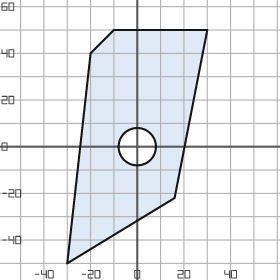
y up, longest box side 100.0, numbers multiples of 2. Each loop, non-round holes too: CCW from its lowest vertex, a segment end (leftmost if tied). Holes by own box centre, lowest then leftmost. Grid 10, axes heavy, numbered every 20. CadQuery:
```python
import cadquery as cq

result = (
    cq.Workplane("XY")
    .moveTo(-30.0, -50.0)
    .lineTo(16.0, -22.0)
    .lineTo(30.0, 50.0)
    .lineTo(-10.0, 50.0)
    .lineTo(-20.0, 40.0)
    .close()
    .moveTo(0.0, 0.0)
    .circle(8.0)
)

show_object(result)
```